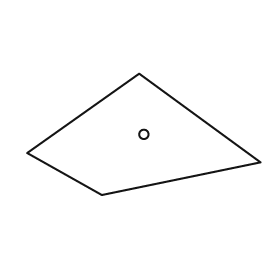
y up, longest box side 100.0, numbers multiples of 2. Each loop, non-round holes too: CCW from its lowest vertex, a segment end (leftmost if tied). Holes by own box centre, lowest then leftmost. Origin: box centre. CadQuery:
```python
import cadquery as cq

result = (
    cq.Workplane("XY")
    .moveTo(-18.0, -26.0)
    .lineTo(50.0, -12.0)
    .lineTo(-2.0, 26.0)
    .lineTo(-50.0, -8.0)
    .close()
    .moveTo(0.0, 0.0)
    .circle(2.0)
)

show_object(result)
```